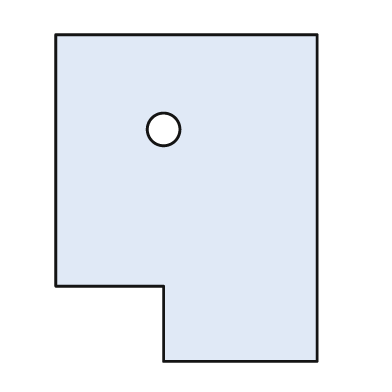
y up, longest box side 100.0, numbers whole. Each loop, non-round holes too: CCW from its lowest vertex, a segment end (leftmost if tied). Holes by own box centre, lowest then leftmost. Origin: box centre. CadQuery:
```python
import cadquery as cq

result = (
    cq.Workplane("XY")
    .moveTo(-7.0, -50.0)
    .lineTo(40.0, -50.0)
    .lineTo(40.0, 50.0)
    .lineTo(-40.0, 50.0)
    .lineTo(-40.0, -27.0)
    .lineTo(-7.0, -27.0)
    .close()
    .moveTo(-7.0, 21.0)
    .circle(5.0)
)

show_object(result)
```